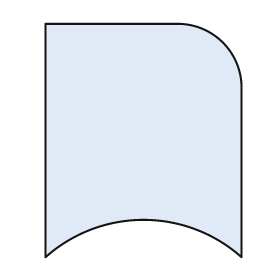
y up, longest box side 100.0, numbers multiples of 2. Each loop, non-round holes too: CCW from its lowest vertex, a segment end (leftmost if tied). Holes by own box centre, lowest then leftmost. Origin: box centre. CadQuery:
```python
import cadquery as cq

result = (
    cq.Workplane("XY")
    .moveTo(-42.0, -50.0)
    .threePointArc((0.0, -34.0), (42.0, -50.0))
    .lineTo(42.0, 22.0)
    .threePointArc((34.0, 42.0), (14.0, 50.0))
    .lineTo(-42.0, 50.0)
    .close()
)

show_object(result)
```